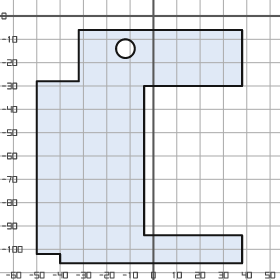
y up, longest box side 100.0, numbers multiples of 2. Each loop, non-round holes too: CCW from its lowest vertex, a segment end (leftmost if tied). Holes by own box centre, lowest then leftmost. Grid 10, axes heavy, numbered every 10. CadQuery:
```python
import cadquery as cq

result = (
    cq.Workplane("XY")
    .moveTo(-40.0, -106.0)
    .lineTo(38.0, -106.0)
    .lineTo(38.0, -94.0)
    .lineTo(-4.0, -94.0)
    .lineTo(-4.0, -30.0)
    .lineTo(38.0, -30.0)
    .lineTo(38.0, -6.0)
    .lineTo(-32.0, -6.0)
    .lineTo(-32.0, -28.0)
    .lineTo(-50.0, -28.0)
    .lineTo(-50.0, -102.0)
    .lineTo(-40.0, -102.0)
    .close()
    .moveTo(-12.0, -14.0)
    .circle(4.0)
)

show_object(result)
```